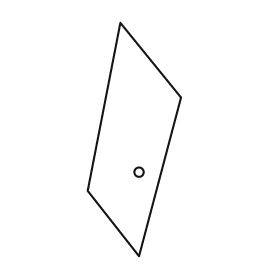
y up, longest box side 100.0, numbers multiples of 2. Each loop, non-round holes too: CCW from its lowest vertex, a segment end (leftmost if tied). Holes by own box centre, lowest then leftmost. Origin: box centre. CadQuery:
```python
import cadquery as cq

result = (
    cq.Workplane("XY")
    .moveTo(2.0, -50.0)
    .lineTo(20.0, 18.0)
    .lineTo(-6.0, 50.0)
    .lineTo(-20.0, -22.0)
    .close()
    .moveTo(2.0, -14.0)
    .circle(2.0)
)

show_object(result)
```